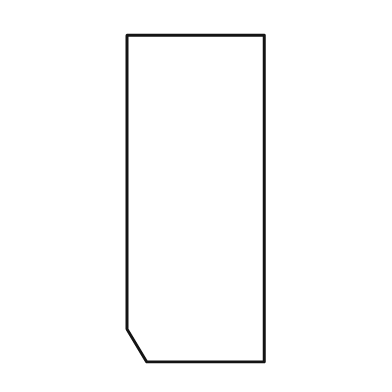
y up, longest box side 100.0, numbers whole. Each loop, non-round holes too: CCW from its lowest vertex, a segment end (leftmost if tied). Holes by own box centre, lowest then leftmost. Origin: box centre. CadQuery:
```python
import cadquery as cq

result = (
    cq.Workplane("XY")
    .moveTo(-15.0, -50.0)
    .lineTo(21.0, -50.0)
    .lineTo(21.0, 50.0)
    .lineTo(-21.0, 50.0)
    .lineTo(-21.0, -40.0)
    .close()
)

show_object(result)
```